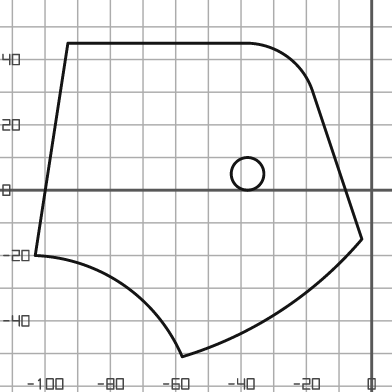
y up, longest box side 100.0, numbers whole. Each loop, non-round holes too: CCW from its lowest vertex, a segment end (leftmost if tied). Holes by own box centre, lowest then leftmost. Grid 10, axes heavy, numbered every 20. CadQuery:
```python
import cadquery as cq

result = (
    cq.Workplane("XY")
    .moveTo(-58.0, -51.0)
    .threePointArc((-28.0, -37.0), (-3.0, -15.0))
    .lineTo(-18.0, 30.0)
    .threePointArc((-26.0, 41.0), (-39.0, 45.0))
    .lineTo(-93.0, 45.0)
    .lineTo(-103.0, -20.0)
    .threePointArc((-76.0, -29.0), (-58.0, -51.0))
    .close()
    .moveTo(-38.0, 5.0)
    .circle(5.0)
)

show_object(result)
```